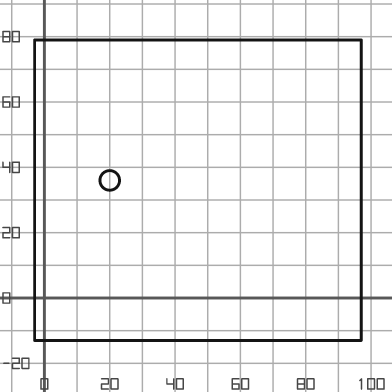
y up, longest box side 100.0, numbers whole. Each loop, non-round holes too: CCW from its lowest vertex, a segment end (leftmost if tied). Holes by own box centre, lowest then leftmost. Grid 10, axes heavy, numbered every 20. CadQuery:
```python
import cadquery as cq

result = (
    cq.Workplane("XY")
    .moveTo(-3.0, -13.0)
    .lineTo(97.0, -13.0)
    .lineTo(97.0, 79.0)
    .lineTo(-3.0, 79.0)
    .close()
    .moveTo(20.0, 36.0)
    .circle(3.0)
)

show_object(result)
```